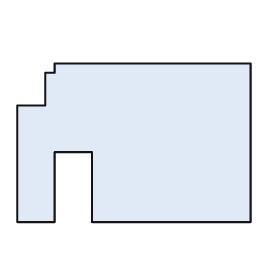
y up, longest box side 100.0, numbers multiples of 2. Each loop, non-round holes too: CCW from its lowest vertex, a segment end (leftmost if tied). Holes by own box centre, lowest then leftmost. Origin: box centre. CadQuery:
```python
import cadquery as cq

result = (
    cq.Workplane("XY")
    .moveTo(-50.0, -34.0)
    .lineTo(-34.0, -34.0)
    .lineTo(-34.0, -4.0)
    .lineTo(-18.0, -4.0)
    .lineTo(-18.0, -34.0)
    .lineTo(50.0, -34.0)
    .lineTo(50.0, 34.0)
    .lineTo(-34.0, 34.0)
    .lineTo(-34.0, 30.0)
    .lineTo(-38.0, 30.0)
    .lineTo(-38.0, 16.0)
    .lineTo(-50.0, 16.0)
    .close()
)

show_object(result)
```